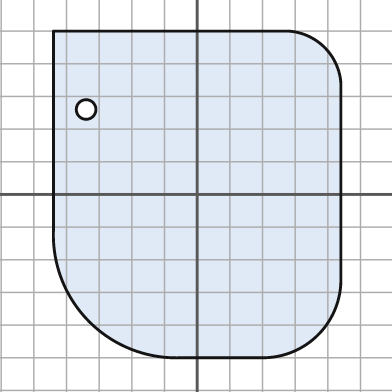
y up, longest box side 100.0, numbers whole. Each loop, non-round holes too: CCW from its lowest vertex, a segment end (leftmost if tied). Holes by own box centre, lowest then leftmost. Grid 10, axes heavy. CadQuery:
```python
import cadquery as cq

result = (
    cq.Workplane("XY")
    .moveTo(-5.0, -50.0)
    .lineTo(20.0, -50.0)
    .threePointArc((37.0, -43.0), (44.0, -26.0))
    .lineTo(44.0, 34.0)
    .threePointArc((39.0, 45.0), (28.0, 50.0))
    .lineTo(-44.0, 50.0)
    .lineTo(-44.0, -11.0)
    .threePointArc((-33.0, -39.0), (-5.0, -50.0))
    .close()
    .moveTo(-34.0, 26.0)
    .circle(3.0)
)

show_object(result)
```